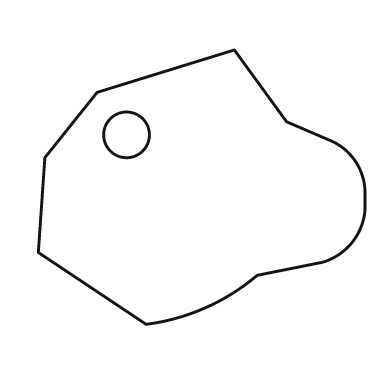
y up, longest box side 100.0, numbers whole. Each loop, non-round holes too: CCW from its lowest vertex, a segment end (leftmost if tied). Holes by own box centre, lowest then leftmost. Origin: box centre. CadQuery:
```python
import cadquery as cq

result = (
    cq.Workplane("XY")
    .moveTo(-17.0, -42.0)
    .threePointArc((1.0, -37.0), (17.0, -27.0))
    .lineTo(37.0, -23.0)
    .threePointArc((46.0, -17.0), (50.0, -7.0))
    .lineTo(50.0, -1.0)
    .threePointArc((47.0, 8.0), (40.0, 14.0))
    .lineTo(26.0, 20.0)
    .lineTo(10.0, 42.0)
    .lineTo(-32.0, 29.0)
    .lineTo(-48.0, 9.0)
    .lineTo(-50.0, -20.0)
    .close()
    .moveTo(-23.0, 16.0)
    .circle(7.0)
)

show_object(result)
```